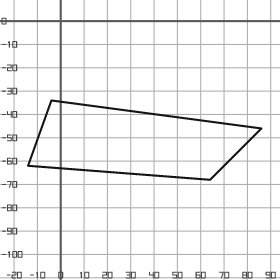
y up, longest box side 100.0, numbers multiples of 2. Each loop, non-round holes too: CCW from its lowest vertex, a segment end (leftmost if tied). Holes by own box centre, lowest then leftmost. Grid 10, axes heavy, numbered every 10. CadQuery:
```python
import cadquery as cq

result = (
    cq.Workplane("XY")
    .moveTo(64.0, -68.0)
    .lineTo(86.0, -46.0)
    .lineTo(-4.0, -34.0)
    .lineTo(-14.0, -62.0)
    .close()
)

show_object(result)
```